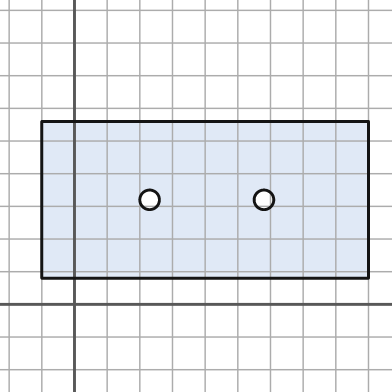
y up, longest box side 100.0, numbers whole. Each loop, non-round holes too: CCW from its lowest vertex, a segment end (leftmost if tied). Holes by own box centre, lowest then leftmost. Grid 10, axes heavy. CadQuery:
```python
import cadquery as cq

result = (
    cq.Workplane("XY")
    .moveTo(-10.0, 8.0)
    .lineTo(90.0, 8.0)
    .lineTo(90.0, 56.0)
    .lineTo(-10.0, 56.0)
    .close()
    .moveTo(23.0, 32.0)
    .circle(3.0)
    .moveTo(58.0, 32.0)
    .circle(3.0)
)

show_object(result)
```